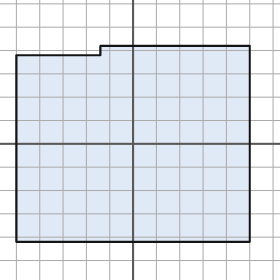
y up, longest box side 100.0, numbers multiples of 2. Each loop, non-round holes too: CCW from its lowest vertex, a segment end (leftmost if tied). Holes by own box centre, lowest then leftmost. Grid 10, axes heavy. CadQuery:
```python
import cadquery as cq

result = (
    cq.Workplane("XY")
    .moveTo(-50.0, -42.0)
    .lineTo(50.0, -42.0)
    .lineTo(50.0, 42.0)
    .lineTo(-14.0, 42.0)
    .lineTo(-14.0, 38.0)
    .lineTo(-50.0, 38.0)
    .close()
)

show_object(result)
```